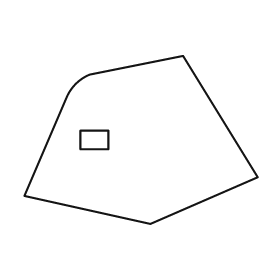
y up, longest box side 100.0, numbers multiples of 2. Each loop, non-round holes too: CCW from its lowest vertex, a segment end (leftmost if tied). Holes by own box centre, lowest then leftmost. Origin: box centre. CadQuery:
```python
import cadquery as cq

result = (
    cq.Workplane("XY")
    .moveTo(4.0, -36.0)
    .lineTo(50.0, -16.0)
    .lineTo(18.0, 36.0)
    .lineTo(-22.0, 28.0)
    .threePointArc((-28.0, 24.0), (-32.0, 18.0))
    .lineTo(-50.0, -24.0)
    .close()
    .moveTo(-26.0, -4.0)
    .lineTo(-14.0, -4.0)
    .lineTo(-14.0, 4.0)
    .lineTo(-26.0, 4.0)
    .close()
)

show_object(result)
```